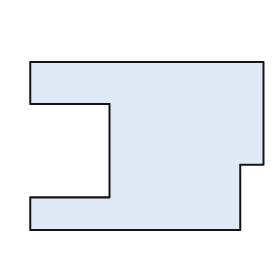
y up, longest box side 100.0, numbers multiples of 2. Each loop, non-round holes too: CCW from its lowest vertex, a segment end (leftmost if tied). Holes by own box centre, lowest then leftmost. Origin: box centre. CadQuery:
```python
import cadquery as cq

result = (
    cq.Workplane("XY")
    .moveTo(-50.0, -36.0)
    .lineTo(40.0, -36.0)
    .lineTo(40.0, -8.0)
    .lineTo(50.0, -8.0)
    .lineTo(50.0, 36.0)
    .lineTo(-50.0, 36.0)
    .lineTo(-50.0, 18.0)
    .lineTo(-16.0, 18.0)
    .lineTo(-16.0, -22.0)
    .lineTo(-50.0, -22.0)
    .close()
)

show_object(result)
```